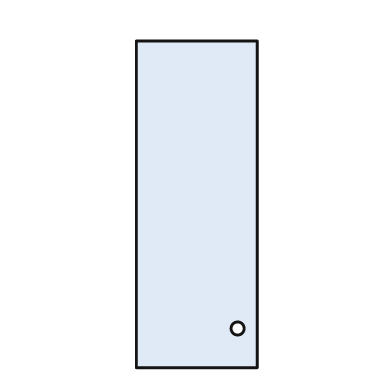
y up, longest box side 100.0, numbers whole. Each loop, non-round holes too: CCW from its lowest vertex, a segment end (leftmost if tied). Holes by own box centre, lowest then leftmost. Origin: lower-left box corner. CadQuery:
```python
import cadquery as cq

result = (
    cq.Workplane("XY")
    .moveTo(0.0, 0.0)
    .lineTo(37.0, 0.0)
    .lineTo(37.0, 100.0)
    .lineTo(0.0, 100.0)
    .close()
    .moveTo(31.0, 12.0)
    .circle(2.0)
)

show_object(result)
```